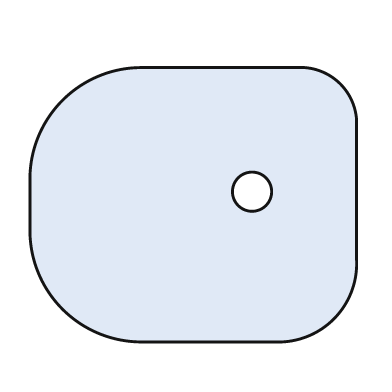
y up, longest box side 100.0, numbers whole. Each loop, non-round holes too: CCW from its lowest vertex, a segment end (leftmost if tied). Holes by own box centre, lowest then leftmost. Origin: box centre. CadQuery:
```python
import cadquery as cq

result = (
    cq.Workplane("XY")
    .moveTo(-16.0, -42.0)
    .lineTo(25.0, -42.0)
    .threePointArc((43.0, -35.0), (50.0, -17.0))
    .lineTo(50.0, 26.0)
    .threePointArc((45.0, 37.0), (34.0, 42.0))
    .lineTo(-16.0, 42.0)
    .threePointArc((-40.0, 32.0), (-50.0, 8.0))
    .lineTo(-50.0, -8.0)
    .threePointArc((-40.0, -32.0), (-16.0, -42.0))
    .close()
    .moveTo(18.0, 4.0)
    .circle(6.0)
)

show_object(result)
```